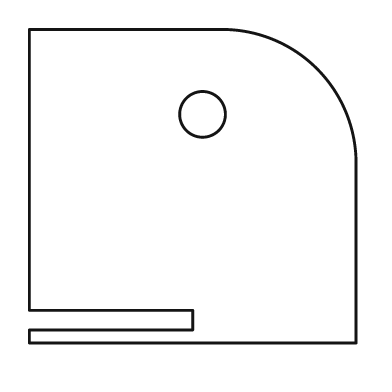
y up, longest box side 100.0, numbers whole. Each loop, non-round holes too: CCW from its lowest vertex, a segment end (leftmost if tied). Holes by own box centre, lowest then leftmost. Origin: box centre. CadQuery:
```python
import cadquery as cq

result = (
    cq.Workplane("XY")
    .moveTo(-50.0, -48.0)
    .lineTo(50.0, -48.0)
    .lineTo(50.0, 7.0)
    .threePointArc((38.0, 36.0), (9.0, 48.0))
    .lineTo(-50.0, 48.0)
    .lineTo(-50.0, -38.0)
    .lineTo(0.0, -38.0)
    .lineTo(0.0, -44.0)
    .lineTo(-50.0, -44.0)
    .close()
    .moveTo(3.0, 22.0)
    .circle(7.0)
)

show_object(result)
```